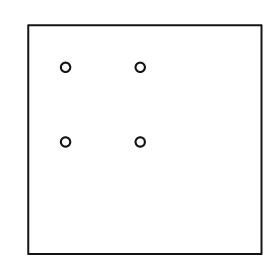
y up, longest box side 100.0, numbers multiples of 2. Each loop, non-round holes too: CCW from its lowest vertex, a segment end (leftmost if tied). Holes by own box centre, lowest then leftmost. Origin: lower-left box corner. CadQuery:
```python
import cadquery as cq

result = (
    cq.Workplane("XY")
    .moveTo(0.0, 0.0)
    .lineTo(100.0, 0.0)
    .lineTo(100.0, 98.0)
    .lineTo(0.0, 98.0)
    .close()
    .moveTo(16.0, 48.0)
    .circle(2.0)
    .moveTo(48.0, 48.0)
    .circle(2.0)
    .moveTo(16.0, 80.0)
    .circle(2.0)
    .moveTo(48.0, 80.0)
    .circle(2.0)
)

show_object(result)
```